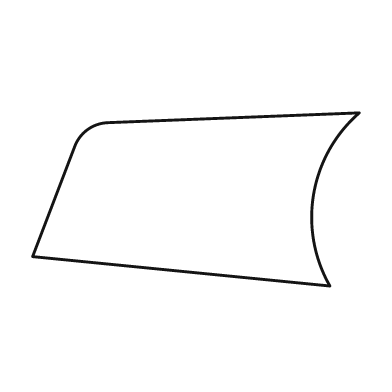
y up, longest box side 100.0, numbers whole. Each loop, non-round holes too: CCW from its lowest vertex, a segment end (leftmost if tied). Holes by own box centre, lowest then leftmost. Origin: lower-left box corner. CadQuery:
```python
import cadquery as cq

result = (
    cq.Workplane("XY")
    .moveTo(91.0, 0.0)
    .threePointArc((86.0, 28.0), (100.0, 53.0))
    .lineTo(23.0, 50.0)
    .threePointArc((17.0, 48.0), (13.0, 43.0))
    .lineTo(0.0, 9.0)
    .close()
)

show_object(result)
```